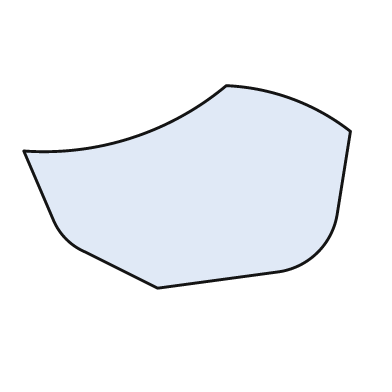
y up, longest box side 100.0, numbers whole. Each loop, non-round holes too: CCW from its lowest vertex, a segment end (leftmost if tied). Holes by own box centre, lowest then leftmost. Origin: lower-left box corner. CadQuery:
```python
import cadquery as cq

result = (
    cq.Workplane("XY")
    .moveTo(41.0, 0.0)
    .lineTo(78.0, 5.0)
    .threePointArc((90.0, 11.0), (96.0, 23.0))
    .lineTo(100.0, 48.0)
    .threePointArc((82.0, 58.0), (62.0, 62.0))
    .threePointArc((33.0, 46.0), (0.0, 42.0))
    .lineTo(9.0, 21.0)
    .threePointArc((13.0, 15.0), (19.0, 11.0))
    .close()
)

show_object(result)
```